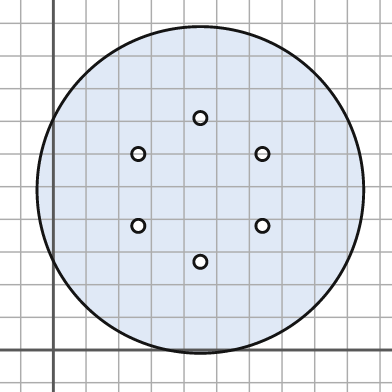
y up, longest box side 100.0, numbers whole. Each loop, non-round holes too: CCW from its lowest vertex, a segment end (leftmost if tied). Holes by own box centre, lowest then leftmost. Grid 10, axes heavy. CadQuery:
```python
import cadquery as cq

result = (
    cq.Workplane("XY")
    .moveTo(45.0, 49.0)
    .circle(50.0)
    .moveTo(45.0, 27.0)
    .circle(2.0)
    .moveTo(26.0, 38.0)
    .circle(2.0)
    .moveTo(64.0, 38.0)
    .circle(2.0)
    .moveTo(26.0, 60.0)
    .circle(2.0)
    .moveTo(64.0, 60.0)
    .circle(2.0)
    .moveTo(45.0, 71.0)
    .circle(2.0)
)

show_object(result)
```